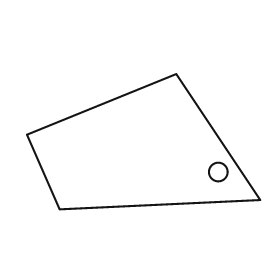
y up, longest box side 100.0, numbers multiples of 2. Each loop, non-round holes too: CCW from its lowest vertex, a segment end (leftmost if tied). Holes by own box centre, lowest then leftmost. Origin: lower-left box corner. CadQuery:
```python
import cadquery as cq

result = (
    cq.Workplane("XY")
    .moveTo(14.0, 0.0)
    .lineTo(100.0, 4.0)
    .lineTo(64.0, 58.0)
    .lineTo(0.0, 32.0)
    .close()
    .moveTo(82.0, 16.0)
    .circle(4.0)
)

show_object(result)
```